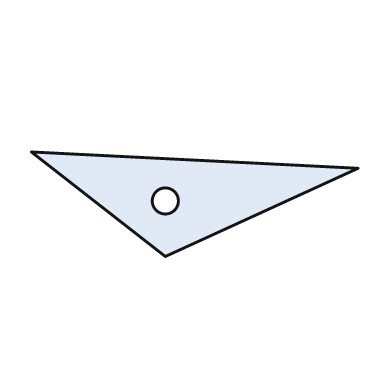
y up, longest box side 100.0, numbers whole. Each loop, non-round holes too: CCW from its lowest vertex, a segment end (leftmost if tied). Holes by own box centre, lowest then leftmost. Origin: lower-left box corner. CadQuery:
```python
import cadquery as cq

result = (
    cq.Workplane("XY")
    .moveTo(41.0, 0.0)
    .lineTo(100.0, 27.0)
    .lineTo(0.0, 32.0)
    .close()
    .moveTo(41.0, 17.0)
    .circle(4.0)
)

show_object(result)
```